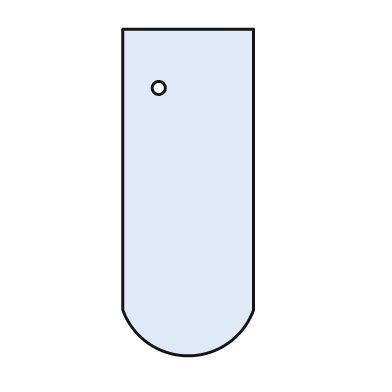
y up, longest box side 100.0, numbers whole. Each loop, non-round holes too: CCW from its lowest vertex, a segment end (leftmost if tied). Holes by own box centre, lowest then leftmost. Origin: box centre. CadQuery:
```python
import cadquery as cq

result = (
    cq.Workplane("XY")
    .moveTo(-20.0, -36.0)
    .threePointArc((0.0, -50.0), (20.0, -36.0))
    .lineTo(20.0, 50.0)
    .lineTo(-20.0, 50.0)
    .close()
    .moveTo(-9.0, 32.0)
    .circle(2.0)
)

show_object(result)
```